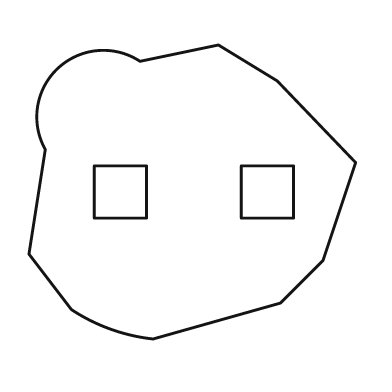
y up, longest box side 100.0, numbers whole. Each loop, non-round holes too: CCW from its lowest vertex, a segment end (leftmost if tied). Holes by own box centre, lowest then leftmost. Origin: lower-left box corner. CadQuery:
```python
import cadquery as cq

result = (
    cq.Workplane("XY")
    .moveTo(38.0, 0.0)
    .lineTo(77.0, 11.0)
    .lineTo(90.0, 24.0)
    .lineTo(100.0, 54.0)
    .lineTo(76.0, 79.0)
    .lineTo(58.0, 90.0)
    .lineTo(34.0, 85.0)
    .threePointArc((9.0, 83.0), (5.0, 58.0))
    .lineTo(0.0, 26.0)
    .lineTo(13.0, 9.0)
    .threePointArc((25.0, 3.0), (38.0, 0.0))
    .close()
    .moveTo(20.0, 37.0)
    .lineTo(36.0, 37.0)
    .lineTo(36.0, 53.0)
    .lineTo(20.0, 53.0)
    .close()
    .moveTo(65.0, 37.0)
    .lineTo(81.0, 37.0)
    .lineTo(81.0, 53.0)
    .lineTo(65.0, 53.0)
    .close()
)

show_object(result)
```